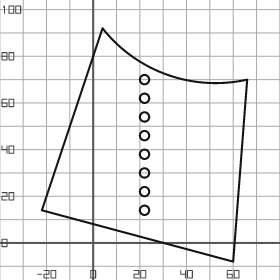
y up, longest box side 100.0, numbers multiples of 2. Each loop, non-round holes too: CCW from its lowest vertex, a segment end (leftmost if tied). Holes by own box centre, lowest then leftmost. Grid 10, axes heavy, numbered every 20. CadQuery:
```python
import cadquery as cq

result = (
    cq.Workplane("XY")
    .moveTo(60.0, -8.0)
    .lineTo(66.0, 70.0)
    .threePointArc((32.0, 72.0), (4.0, 92.0))
    .lineTo(-22.0, 14.0)
    .close()
    .moveTo(22.0, 14.0)
    .circle(2.0)
    .moveTo(22.0, 22.0)
    .circle(2.0)
    .moveTo(22.0, 30.0)
    .circle(2.0)
    .moveTo(22.0, 38.0)
    .circle(2.0)
    .moveTo(22.0, 46.0)
    .circle(2.0)
    .moveTo(22.0, 54.0)
    .circle(2.0)
    .moveTo(22.0, 62.0)
    .circle(2.0)
    .moveTo(22.0, 70.0)
    .circle(2.0)
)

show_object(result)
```